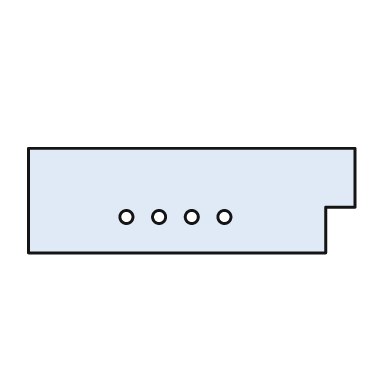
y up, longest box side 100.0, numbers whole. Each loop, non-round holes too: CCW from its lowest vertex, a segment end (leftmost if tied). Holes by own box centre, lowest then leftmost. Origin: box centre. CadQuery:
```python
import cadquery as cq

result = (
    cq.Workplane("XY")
    .moveTo(-50.0, -16.0)
    .lineTo(41.0, -16.0)
    .lineTo(41.0, -2.0)
    .lineTo(50.0, -2.0)
    .lineTo(50.0, 16.0)
    .lineTo(-50.0, 16.0)
    .close()
    .moveTo(-20.0, -5.0)
    .circle(2.0)
    .moveTo(-10.0, -5.0)
    .circle(2.0)
    .moveTo(0.0, -5.0)
    .circle(2.0)
    .moveTo(10.0, -5.0)
    .circle(2.0)
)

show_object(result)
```